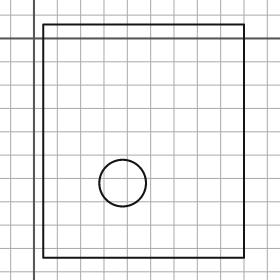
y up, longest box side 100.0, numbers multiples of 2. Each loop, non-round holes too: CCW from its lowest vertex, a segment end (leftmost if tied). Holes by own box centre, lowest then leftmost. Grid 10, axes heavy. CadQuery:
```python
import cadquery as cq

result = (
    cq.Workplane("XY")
    .moveTo(4.0, -94.0)
    .lineTo(90.0, -94.0)
    .lineTo(90.0, 6.0)
    .lineTo(4.0, 6.0)
    .close()
    .moveTo(38.0, -62.0)
    .circle(10.0)
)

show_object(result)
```